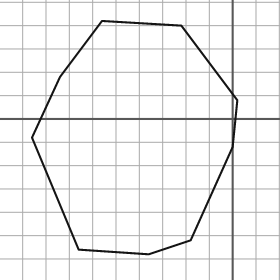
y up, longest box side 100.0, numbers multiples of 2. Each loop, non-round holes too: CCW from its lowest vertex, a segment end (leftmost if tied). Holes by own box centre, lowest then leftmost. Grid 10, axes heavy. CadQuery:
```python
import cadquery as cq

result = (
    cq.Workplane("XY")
    .moveTo(-36.0, -58.0)
    .lineTo(-18.0, -52.0)
    .lineTo(0.0, -12.0)
    .lineTo(2.0, 8.0)
    .lineTo(-22.0, 40.0)
    .lineTo(-56.0, 42.0)
    .lineTo(-74.0, 18.0)
    .lineTo(-86.0, -8.0)
    .lineTo(-66.0, -56.0)
    .close()
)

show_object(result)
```